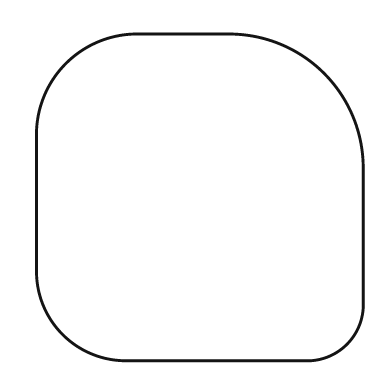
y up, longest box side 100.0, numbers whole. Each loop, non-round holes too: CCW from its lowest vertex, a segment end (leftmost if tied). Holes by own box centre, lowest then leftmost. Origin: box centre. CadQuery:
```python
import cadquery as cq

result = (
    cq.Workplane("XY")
    .moveTo(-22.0, -50.0)
    .lineTo(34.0, -50.0)
    .threePointArc((45.0, -45.0), (50.0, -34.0))
    .lineTo(50.0, 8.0)
    .threePointArc((38.0, 38.0), (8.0, 50.0))
    .lineTo(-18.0, 50.0)
    .threePointArc((-41.0, 41.0), (-50.0, 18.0))
    .lineTo(-50.0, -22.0)
    .threePointArc((-42.0, -42.0), (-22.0, -50.0))
    .close()
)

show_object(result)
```